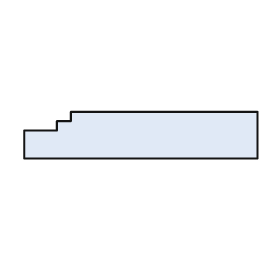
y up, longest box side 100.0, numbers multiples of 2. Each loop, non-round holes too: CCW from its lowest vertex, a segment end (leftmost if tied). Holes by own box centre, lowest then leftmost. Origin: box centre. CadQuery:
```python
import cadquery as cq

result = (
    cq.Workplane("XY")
    .moveTo(-50.0, -10.0)
    .lineTo(50.0, -10.0)
    .lineTo(50.0, 10.0)
    .lineTo(-30.0, 10.0)
    .lineTo(-30.0, 6.0)
    .lineTo(-36.0, 6.0)
    .lineTo(-36.0, 2.0)
    .lineTo(-50.0, 2.0)
    .close()
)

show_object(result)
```